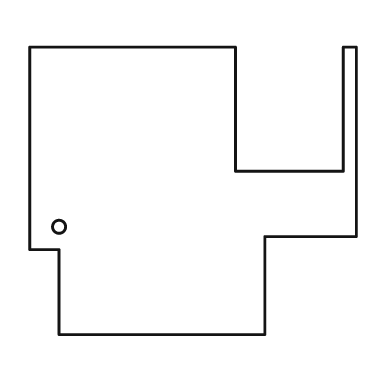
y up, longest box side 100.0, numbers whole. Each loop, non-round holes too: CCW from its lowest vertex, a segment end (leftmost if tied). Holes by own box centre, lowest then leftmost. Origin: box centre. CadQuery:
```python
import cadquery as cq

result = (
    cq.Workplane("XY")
    .moveTo(-41.0, -44.0)
    .lineTo(22.0, -44.0)
    .lineTo(22.0, -14.0)
    .lineTo(50.0, -14.0)
    .lineTo(50.0, 44.0)
    .lineTo(46.0, 44.0)
    .lineTo(46.0, 6.0)
    .lineTo(13.0, 6.0)
    .lineTo(13.0, 44.0)
    .lineTo(-50.0, 44.0)
    .lineTo(-50.0, -18.0)
    .lineTo(-41.0, -18.0)
    .close()
    .moveTo(-41.0, -11.0)
    .circle(2.0)
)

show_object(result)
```